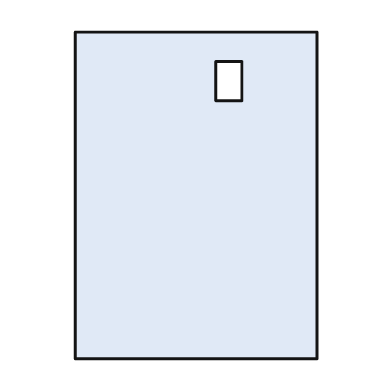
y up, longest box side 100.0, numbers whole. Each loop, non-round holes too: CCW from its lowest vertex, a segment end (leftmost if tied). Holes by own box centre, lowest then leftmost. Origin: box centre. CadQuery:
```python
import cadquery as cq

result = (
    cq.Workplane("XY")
    .moveTo(-37.0, -50.0)
    .lineTo(37.0, -50.0)
    .lineTo(37.0, 50.0)
    .lineTo(-37.0, 50.0)
    .close()
    .moveTo(6.0, 29.0)
    .lineTo(14.0, 29.0)
    .lineTo(14.0, 41.0)
    .lineTo(6.0, 41.0)
    .close()
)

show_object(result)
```